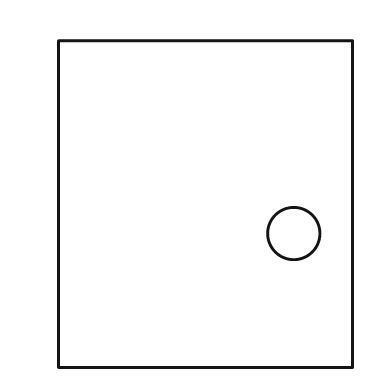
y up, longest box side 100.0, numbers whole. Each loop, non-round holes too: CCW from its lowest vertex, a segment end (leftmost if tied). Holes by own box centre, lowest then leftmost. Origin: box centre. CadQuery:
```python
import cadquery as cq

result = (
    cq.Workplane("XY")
    .moveTo(-45.0, -50.0)
    .lineTo(45.0, -50.0)
    .lineTo(45.0, 50.0)
    .lineTo(-45.0, 50.0)
    .close()
    .moveTo(27.0, -9.0)
    .circle(8.0)
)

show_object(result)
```